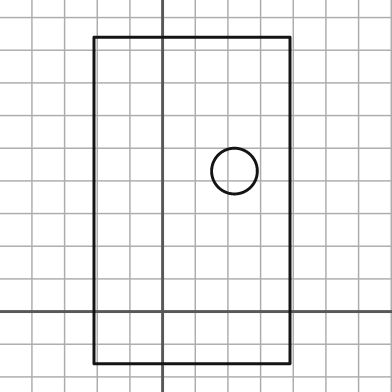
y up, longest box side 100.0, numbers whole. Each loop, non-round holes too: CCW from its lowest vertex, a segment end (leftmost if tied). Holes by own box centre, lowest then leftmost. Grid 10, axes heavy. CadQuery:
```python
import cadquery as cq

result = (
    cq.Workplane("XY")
    .moveTo(-21.0, -16.0)
    .lineTo(39.0, -16.0)
    .lineTo(39.0, 84.0)
    .lineTo(-21.0, 84.0)
    .close()
    .moveTo(22.0, 43.0)
    .circle(7.0)
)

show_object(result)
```